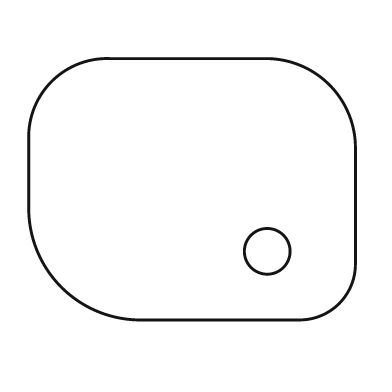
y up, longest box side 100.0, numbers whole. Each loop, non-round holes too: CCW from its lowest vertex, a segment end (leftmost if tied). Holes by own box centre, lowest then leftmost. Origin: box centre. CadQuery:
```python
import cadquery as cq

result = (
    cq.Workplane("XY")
    .moveTo(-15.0, -40.0)
    .lineTo(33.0, -40.0)
    .threePointArc((45.0, -35.0), (50.0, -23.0))
    .lineTo(50.0, 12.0)
    .threePointArc((42.0, 32.0), (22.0, 40.0))
    .lineTo(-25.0, 40.0)
    .threePointArc((-43.0, 33.0), (-50.0, 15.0))
    .lineTo(-50.0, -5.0)
    .threePointArc((-40.0, -30.0), (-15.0, -40.0))
    .close()
    .moveTo(23.0, -19.0)
    .circle(7.0)
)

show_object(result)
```